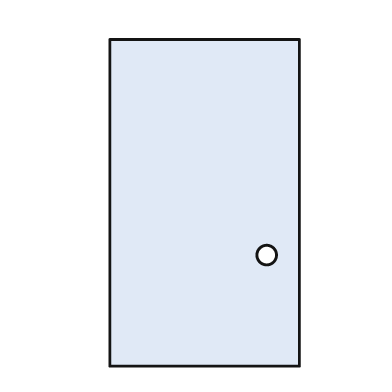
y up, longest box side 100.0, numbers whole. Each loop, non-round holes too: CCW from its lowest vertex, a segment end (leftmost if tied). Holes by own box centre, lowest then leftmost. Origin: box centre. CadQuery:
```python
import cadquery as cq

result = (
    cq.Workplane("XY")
    .moveTo(-29.0, -50.0)
    .lineTo(29.0, -50.0)
    .lineTo(29.0, 50.0)
    .lineTo(-29.0, 50.0)
    .close()
    .moveTo(19.0, -16.0)
    .circle(3.0)
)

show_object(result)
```